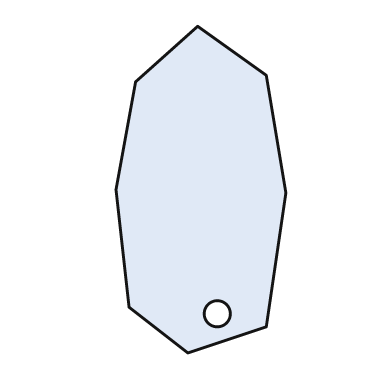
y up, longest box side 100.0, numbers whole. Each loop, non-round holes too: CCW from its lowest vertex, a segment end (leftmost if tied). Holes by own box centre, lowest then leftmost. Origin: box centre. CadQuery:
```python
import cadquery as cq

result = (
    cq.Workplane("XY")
    .moveTo(-4.0, -50.0)
    .lineTo(20.0, -42.0)
    .lineTo(26.0, -1.0)
    .lineTo(20.0, 35.0)
    .lineTo(-1.0, 50.0)
    .lineTo(-20.0, 33.0)
    .lineTo(-26.0, 0.0)
    .lineTo(-22.0, -36.0)
    .close()
    .moveTo(5.0, -38.0)
    .circle(4.0)
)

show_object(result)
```